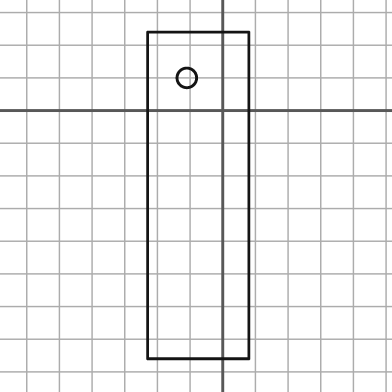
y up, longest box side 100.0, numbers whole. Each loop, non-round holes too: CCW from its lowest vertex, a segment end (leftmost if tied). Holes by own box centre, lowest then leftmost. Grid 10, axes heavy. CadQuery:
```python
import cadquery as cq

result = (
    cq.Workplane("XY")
    .moveTo(-23.0, -76.0)
    .lineTo(8.0, -76.0)
    .lineTo(8.0, 24.0)
    .lineTo(-23.0, 24.0)
    .close()
    .moveTo(-11.0, 10.0)
    .circle(3.0)
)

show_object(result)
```